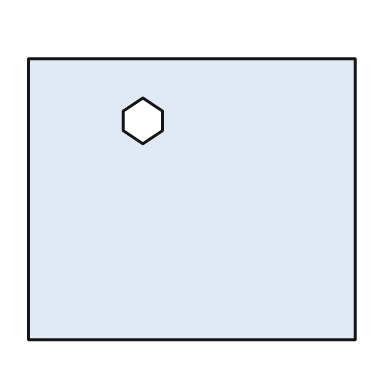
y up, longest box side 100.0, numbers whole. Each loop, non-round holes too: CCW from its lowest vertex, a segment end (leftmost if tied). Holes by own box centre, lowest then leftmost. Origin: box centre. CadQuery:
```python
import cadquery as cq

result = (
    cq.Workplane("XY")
    .moveTo(-50.0, -43.0)
    .lineTo(50.0, -43.0)
    .lineTo(50.0, 43.0)
    .lineTo(-50.0, 43.0)
    .close()
    .moveTo(-15.0, 17.0)
    .lineTo(-9.0, 21.0)
    .lineTo(-9.0, 27.0)
    .lineTo(-15.0, 31.0)
    .lineTo(-21.0, 27.0)
    .lineTo(-21.0, 21.0)
    .close()
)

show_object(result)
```